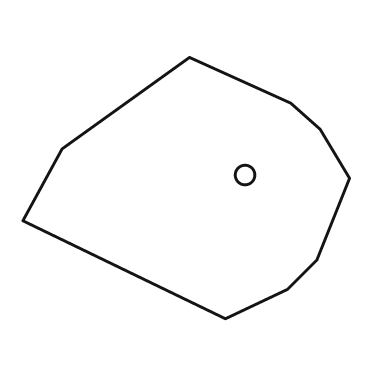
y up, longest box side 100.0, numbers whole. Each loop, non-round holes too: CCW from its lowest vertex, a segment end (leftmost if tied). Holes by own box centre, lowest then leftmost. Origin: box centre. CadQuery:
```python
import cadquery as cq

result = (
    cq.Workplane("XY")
    .moveTo(12.0, -40.0)
    .lineTo(31.0, -31.0)
    .lineTo(40.0, -22.0)
    .lineTo(50.0, 3.0)
    .lineTo(41.0, 18.0)
    .lineTo(32.0, 26.0)
    .lineTo(1.0, 40.0)
    .lineTo(-38.0, 12.0)
    .lineTo(-50.0, -10.0)
    .close()
    .moveTo(18.0, 4.0)
    .circle(3.0)
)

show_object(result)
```